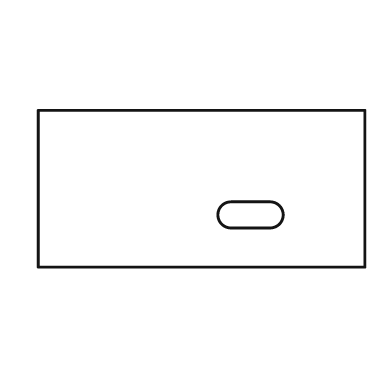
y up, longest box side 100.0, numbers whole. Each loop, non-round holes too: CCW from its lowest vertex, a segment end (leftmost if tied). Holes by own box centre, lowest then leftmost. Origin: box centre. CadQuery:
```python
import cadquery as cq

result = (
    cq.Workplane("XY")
    .moveTo(-50.0, -24.0)
    .lineTo(50.0, -24.0)
    .lineTo(50.0, 24.0)
    .lineTo(-50.0, 24.0)
    .close()
    .moveTo(9.0, -12.0)
    .lineTo(21.0, -12.0)
    .threePointArc((25.0, -8.0), (21.0, -4.0))
    .lineTo(9.0, -4.0)
    .threePointArc((5.0, -8.0), (9.0, -12.0))
    .close()
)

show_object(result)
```